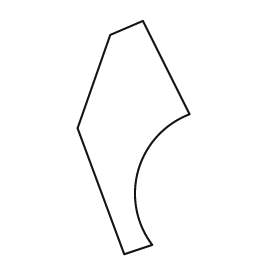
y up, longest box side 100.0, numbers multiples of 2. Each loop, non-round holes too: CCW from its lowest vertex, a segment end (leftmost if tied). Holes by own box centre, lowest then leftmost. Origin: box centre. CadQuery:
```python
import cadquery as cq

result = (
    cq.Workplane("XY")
    .moveTo(-4.0, -50.0)
    .lineTo(8.0, -46.0)
    .threePointArc((2.0, -14.0), (24.0, 10.0))
    .lineTo(4.0, 50.0)
    .lineTo(-10.0, 44.0)
    .lineTo(-24.0, 4.0)
    .close()
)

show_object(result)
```